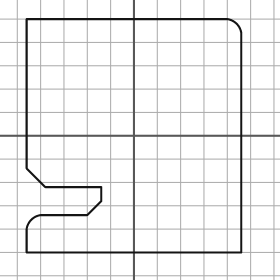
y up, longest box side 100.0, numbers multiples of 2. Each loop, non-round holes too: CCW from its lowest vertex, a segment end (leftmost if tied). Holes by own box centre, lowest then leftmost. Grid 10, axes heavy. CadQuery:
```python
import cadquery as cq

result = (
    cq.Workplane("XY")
    .moveTo(-46.0, -50.0)
    .lineTo(46.0, -50.0)
    .lineTo(46.0, 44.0)
    .threePointArc((44.0, 48.0), (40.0, 50.0))
    .lineTo(-46.0, 50.0)
    .lineTo(-46.0, -14.0)
    .lineTo(-38.0, -22.0)
    .lineTo(-14.0, -22.0)
    .lineTo(-14.0, -28.0)
    .lineTo(-20.0, -34.0)
    .lineTo(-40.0, -34.0)
    .threePointArc((-44.0, -36.0), (-46.0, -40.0))
    .close()
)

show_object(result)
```